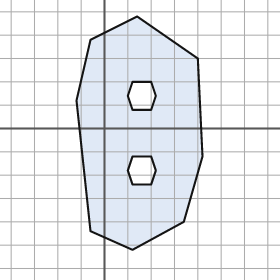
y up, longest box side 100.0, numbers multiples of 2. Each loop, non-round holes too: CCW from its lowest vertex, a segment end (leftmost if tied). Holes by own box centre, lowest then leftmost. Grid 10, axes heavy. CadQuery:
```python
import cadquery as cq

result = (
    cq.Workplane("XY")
    .moveTo(12.0, -52.0)
    .lineTo(34.0, -40.0)
    .lineTo(42.0, -12.0)
    .lineTo(40.0, 30.0)
    .lineTo(14.0, 48.0)
    .lineTo(-6.0, 38.0)
    .lineTo(-12.0, 12.0)
    .lineTo(-6.0, -44.0)
    .close()
    .moveTo(12.0, -24.0)
    .lineTo(20.0, -24.0)
    .lineTo(22.0, -18.0)
    .lineTo(20.0, -12.0)
    .lineTo(12.0, -12.0)
    .lineTo(10.0, -18.0)
    .close()
    .moveTo(12.0, 8.0)
    .lineTo(20.0, 8.0)
    .lineTo(22.0, 14.0)
    .lineTo(20.0, 20.0)
    .lineTo(12.0, 20.0)
    .lineTo(10.0, 14.0)
    .close()
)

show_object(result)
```